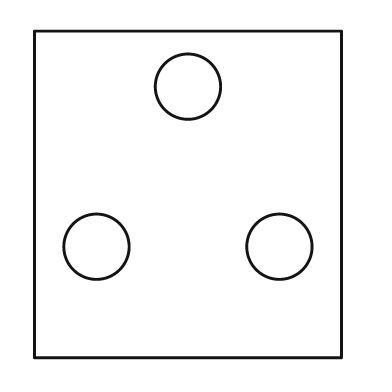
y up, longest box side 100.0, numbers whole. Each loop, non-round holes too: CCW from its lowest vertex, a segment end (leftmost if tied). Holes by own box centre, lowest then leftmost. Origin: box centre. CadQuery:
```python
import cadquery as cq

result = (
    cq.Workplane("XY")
    .moveTo(-47.0, -50.0)
    .lineTo(47.0, -50.0)
    .lineTo(47.0, 50.0)
    .lineTo(-47.0, 50.0)
    .close()
    .moveTo(-28.0, -16.0)
    .circle(10.0)
    .moveTo(28.0, -16.0)
    .circle(10.0)
    .moveTo(0.0, 33.0)
    .circle(10.0)
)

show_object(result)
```